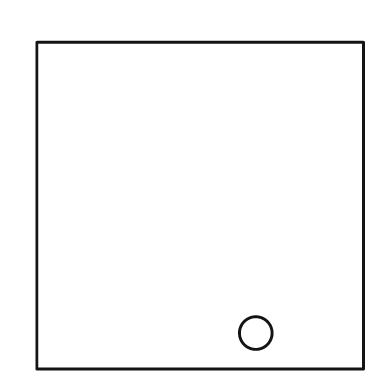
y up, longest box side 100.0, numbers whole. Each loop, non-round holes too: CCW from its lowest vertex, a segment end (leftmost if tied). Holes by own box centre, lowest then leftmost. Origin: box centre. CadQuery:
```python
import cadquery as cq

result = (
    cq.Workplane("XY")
    .moveTo(-50.0, -50.0)
    .lineTo(50.0, -50.0)
    .lineTo(50.0, 50.0)
    .lineTo(-50.0, 50.0)
    .close()
    .moveTo(17.0, -39.0)
    .circle(5.0)
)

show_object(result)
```